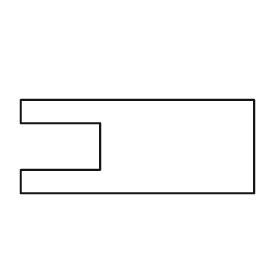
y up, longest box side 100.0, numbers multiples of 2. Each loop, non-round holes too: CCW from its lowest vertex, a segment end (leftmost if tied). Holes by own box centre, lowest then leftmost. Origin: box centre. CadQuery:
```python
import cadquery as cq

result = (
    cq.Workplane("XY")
    .moveTo(-50.0, -20.0)
    .lineTo(50.0, -20.0)
    .lineTo(50.0, 20.0)
    .lineTo(-50.0, 20.0)
    .lineTo(-50.0, 10.0)
    .lineTo(-16.0, 10.0)
    .lineTo(-16.0, -10.0)
    .lineTo(-50.0, -10.0)
    .close()
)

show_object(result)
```